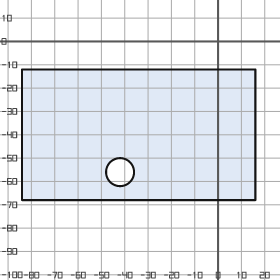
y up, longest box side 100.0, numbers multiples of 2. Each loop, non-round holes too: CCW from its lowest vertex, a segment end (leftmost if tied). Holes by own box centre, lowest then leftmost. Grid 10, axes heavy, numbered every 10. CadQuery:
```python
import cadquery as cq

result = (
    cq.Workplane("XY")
    .moveTo(-84.0, -68.0)
    .lineTo(16.0, -68.0)
    .lineTo(16.0, -12.0)
    .lineTo(-84.0, -12.0)
    .close()
    .moveTo(-42.0, -56.0)
    .circle(6.0)
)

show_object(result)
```